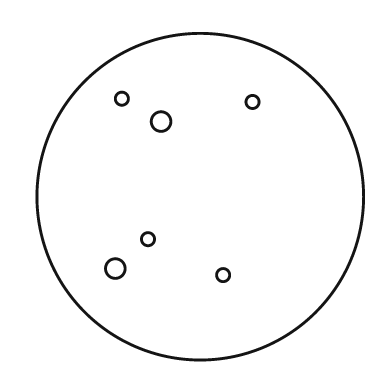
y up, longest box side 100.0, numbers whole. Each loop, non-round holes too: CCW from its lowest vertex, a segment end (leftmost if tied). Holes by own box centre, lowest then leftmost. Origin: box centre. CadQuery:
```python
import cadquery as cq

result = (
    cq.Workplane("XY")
    .moveTo(0.0, 0.0)
    .circle(50.0)
    .moveTo(7.0, -24.0)
    .circle(2.0)
    .moveTo(-26.0, -22.0)
    .circle(3.0)
    .moveTo(-16.0, -13.0)
    .circle(2.0)
    .moveTo(-12.0, 23.0)
    .circle(3.0)
    .moveTo(16.0, 29.0)
    .circle(2.0)
    .moveTo(-24.0, 30.0)
    .circle(2.0)
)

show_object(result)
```